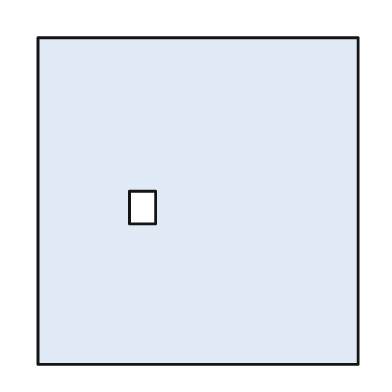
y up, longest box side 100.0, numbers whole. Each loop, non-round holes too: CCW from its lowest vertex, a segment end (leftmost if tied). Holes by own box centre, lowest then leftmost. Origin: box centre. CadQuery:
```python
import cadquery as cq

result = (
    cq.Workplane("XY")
    .moveTo(-49.0, -50.0)
    .lineTo(49.0, -50.0)
    .lineTo(49.0, 50.0)
    .lineTo(-49.0, 50.0)
    .close()
    .moveTo(-21.0, -7.0)
    .lineTo(-13.0, -7.0)
    .lineTo(-13.0, 3.0)
    .lineTo(-21.0, 3.0)
    .close()
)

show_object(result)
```